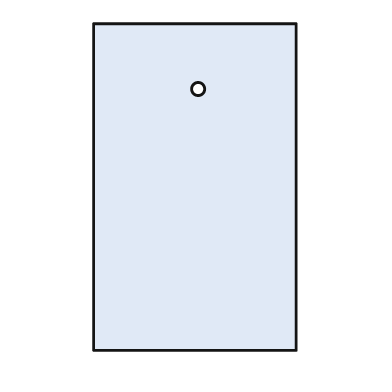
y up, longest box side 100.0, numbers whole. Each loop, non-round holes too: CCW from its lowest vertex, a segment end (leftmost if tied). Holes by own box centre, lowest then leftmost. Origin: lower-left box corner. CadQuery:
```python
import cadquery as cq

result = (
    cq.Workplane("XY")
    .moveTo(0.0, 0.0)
    .lineTo(62.0, 0.0)
    .lineTo(62.0, 100.0)
    .lineTo(0.0, 100.0)
    .close()
    .moveTo(32.0, 80.0)
    .circle(2.0)
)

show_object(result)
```